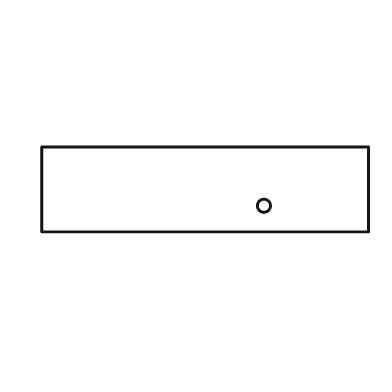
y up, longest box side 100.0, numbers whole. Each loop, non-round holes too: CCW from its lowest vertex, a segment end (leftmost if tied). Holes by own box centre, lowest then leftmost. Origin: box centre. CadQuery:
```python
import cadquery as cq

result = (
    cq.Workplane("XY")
    .moveTo(-50.0, -13.0)
    .lineTo(50.0, -13.0)
    .lineTo(50.0, 13.0)
    .lineTo(-50.0, 13.0)
    .close()
    .moveTo(18.0, -5.0)
    .circle(2.0)
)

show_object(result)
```